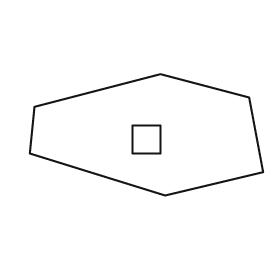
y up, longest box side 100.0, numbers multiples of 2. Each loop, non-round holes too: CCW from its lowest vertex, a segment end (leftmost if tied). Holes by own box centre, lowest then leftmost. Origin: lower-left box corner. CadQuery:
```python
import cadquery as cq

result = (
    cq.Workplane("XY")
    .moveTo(58.0, 0.0)
    .lineTo(100.0, 10.0)
    .lineTo(94.0, 42.0)
    .lineTo(56.0, 52.0)
    .lineTo(2.0, 38.0)
    .lineTo(0.0, 18.0)
    .close()
    .moveTo(44.0, 18.0)
    .lineTo(56.0, 18.0)
    .lineTo(56.0, 30.0)
    .lineTo(44.0, 30.0)
    .close()
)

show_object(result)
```